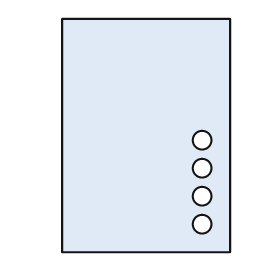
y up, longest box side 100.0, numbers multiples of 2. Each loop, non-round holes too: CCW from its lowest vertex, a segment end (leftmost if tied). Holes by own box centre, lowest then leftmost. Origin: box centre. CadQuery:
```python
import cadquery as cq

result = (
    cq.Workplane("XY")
    .moveTo(-36.0, -50.0)
    .lineTo(36.0, -50.0)
    .lineTo(36.0, 50.0)
    .lineTo(-36.0, 50.0)
    .close()
    .moveTo(24.0, -38.0)
    .circle(4.0)
    .moveTo(24.0, -26.0)
    .circle(4.0)
    .moveTo(24.0, -14.0)
    .circle(4.0)
    .moveTo(24.0, -2.0)
    .circle(4.0)
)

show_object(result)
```